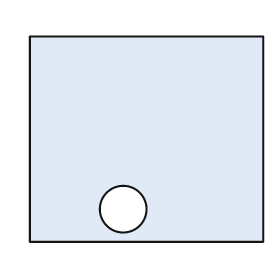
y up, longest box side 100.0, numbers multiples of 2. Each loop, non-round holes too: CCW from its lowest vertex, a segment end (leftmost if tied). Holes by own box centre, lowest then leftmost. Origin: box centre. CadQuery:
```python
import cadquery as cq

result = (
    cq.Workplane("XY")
    .moveTo(-50.0, -44.0)
    .lineTo(50.0, -44.0)
    .lineTo(50.0, 44.0)
    .lineTo(-50.0, 44.0)
    .close()
    .moveTo(-10.0, -30.0)
    .circle(10.0)
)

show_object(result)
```